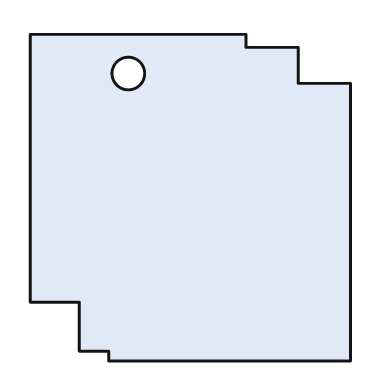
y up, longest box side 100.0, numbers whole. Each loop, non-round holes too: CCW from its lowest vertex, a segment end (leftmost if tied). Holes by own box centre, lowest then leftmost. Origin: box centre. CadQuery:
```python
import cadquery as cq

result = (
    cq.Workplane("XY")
    .moveTo(-25.0, -50.0)
    .lineTo(49.0, -50.0)
    .lineTo(49.0, 35.0)
    .lineTo(33.0, 35.0)
    .lineTo(33.0, 46.0)
    .lineTo(17.0, 46.0)
    .lineTo(17.0, 50.0)
    .lineTo(-49.0, 50.0)
    .lineTo(-49.0, -32.0)
    .lineTo(-34.0, -32.0)
    .lineTo(-34.0, -47.0)
    .lineTo(-25.0, -47.0)
    .close()
    .moveTo(-19.0, 38.0)
    .circle(5.0)
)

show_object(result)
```